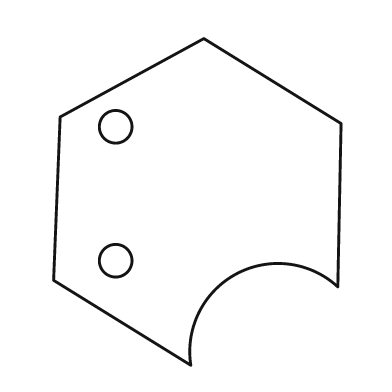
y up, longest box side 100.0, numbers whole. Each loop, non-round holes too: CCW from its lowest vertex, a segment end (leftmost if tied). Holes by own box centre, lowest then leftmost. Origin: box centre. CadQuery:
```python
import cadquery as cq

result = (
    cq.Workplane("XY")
    .moveTo(-2.0, -50.0)
    .threePointArc((12.0, -22.0), (43.0, -26.0))
    .lineTo(44.0, 24.0)
    .lineTo(2.0, 50.0)
    .lineTo(-42.0, 26.0)
    .lineTo(-44.0, -24.0)
    .close()
    .moveTo(-25.0, -18.0)
    .circle(5.0)
    .moveTo(-25.0, 23.0)
    .circle(5.0)
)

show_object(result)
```